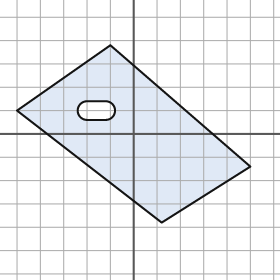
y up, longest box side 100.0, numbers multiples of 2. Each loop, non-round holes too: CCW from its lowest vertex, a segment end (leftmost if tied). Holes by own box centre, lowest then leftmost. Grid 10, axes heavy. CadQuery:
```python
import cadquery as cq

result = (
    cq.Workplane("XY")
    .moveTo(12.0, -38.0)
    .lineTo(50.0, -14.0)
    .lineTo(-10.0, 38.0)
    .lineTo(-50.0, 10.0)
    .close()
    .moveTo(-20.0, 6.0)
    .lineTo(-12.0, 6.0)
    .threePointArc((-8.0, 10.0), (-12.0, 14.0))
    .lineTo(-20.0, 14.0)
    .threePointArc((-24.0, 10.0), (-20.0, 6.0))
    .close()
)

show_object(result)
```